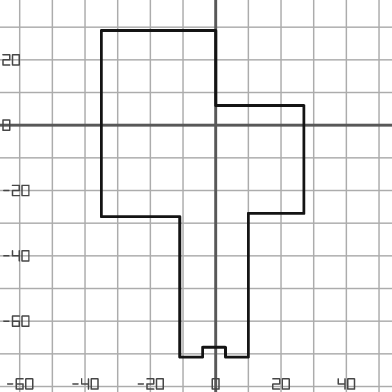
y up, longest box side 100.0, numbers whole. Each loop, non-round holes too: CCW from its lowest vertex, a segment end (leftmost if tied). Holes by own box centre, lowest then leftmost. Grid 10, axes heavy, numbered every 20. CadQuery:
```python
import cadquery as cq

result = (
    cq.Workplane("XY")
    .moveTo(-11.0, -71.0)
    .lineTo(-4.0, -71.0)
    .lineTo(-4.0, -68.0)
    .lineTo(3.0, -68.0)
    .lineTo(3.0, -71.0)
    .lineTo(10.0, -71.0)
    .lineTo(10.0, -27.0)
    .lineTo(27.0, -27.0)
    .lineTo(27.0, 6.0)
    .lineTo(0.0, 6.0)
    .lineTo(0.0, 29.0)
    .lineTo(-35.0, 29.0)
    .lineTo(-35.0, -28.0)
    .lineTo(-11.0, -28.0)
    .close()
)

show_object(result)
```